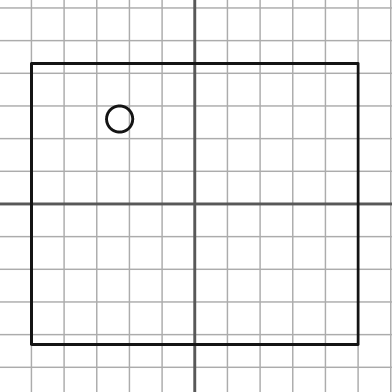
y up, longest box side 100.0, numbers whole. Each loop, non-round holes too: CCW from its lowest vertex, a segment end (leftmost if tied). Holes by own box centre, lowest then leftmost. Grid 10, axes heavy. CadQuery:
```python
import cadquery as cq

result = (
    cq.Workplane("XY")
    .moveTo(-50.0, -43.0)
    .lineTo(50.0, -43.0)
    .lineTo(50.0, 43.0)
    .lineTo(-50.0, 43.0)
    .close()
    .moveTo(-23.0, 26.0)
    .circle(4.0)
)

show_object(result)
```